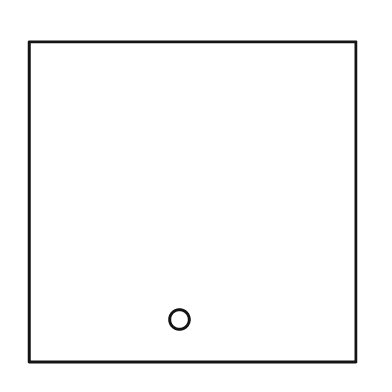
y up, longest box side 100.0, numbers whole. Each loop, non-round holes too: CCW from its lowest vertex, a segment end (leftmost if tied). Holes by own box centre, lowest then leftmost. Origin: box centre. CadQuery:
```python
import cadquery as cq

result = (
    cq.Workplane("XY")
    .moveTo(-50.0, -49.0)
    .lineTo(50.0, -49.0)
    .lineTo(50.0, 49.0)
    .lineTo(-50.0, 49.0)
    .close()
    .moveTo(-4.0, -36.0)
    .circle(3.0)
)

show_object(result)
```